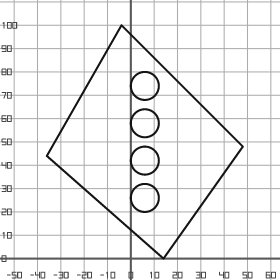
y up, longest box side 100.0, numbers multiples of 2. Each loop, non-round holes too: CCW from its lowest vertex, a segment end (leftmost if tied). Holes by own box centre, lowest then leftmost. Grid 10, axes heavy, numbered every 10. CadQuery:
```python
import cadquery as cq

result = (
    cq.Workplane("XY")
    .moveTo(14.0, 0.0)
    .lineTo(48.0, 48.0)
    .lineTo(-4.0, 100.0)
    .lineTo(-36.0, 44.0)
    .close()
    .moveTo(6.0, 26.0)
    .circle(6.0)
    .moveTo(6.0, 42.0)
    .circle(6.0)
    .moveTo(6.0, 58.0)
    .circle(6.0)
    .moveTo(6.0, 74.0)
    .circle(6.0)
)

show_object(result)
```